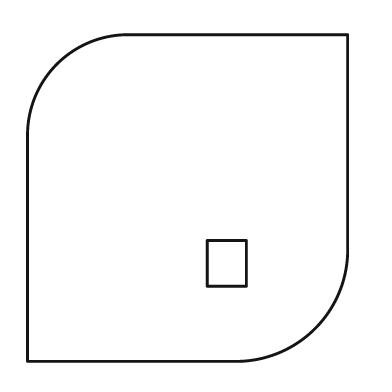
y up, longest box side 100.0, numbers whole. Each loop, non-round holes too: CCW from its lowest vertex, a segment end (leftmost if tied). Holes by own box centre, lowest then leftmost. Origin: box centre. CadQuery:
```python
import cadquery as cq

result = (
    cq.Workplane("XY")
    .moveTo(-49.0, -50.0)
    .lineTo(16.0, -50.0)
    .threePointArc((39.0, -40.0), (49.0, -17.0))
    .lineTo(49.0, 50.0)
    .lineTo(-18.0, 50.0)
    .threePointArc((-40.0, 41.0), (-49.0, 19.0))
    .close()
    .moveTo(6.0, -27.0)
    .lineTo(18.0, -27.0)
    .lineTo(18.0, -13.0)
    .lineTo(6.0, -13.0)
    .close()
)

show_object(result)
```